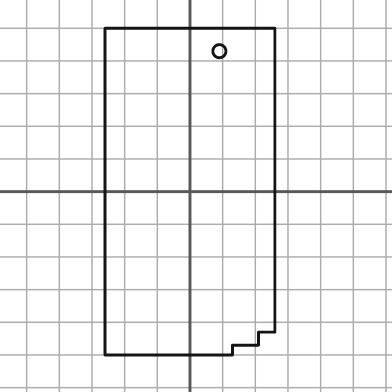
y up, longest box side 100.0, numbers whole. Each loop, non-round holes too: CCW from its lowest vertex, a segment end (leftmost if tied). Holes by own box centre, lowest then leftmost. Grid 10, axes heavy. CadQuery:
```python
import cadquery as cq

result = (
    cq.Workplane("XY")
    .moveTo(-26.0, -50.0)
    .lineTo(13.0, -50.0)
    .lineTo(13.0, -47.0)
    .lineTo(21.0, -47.0)
    .lineTo(21.0, -43.0)
    .lineTo(26.0, -43.0)
    .lineTo(26.0, 50.0)
    .lineTo(-26.0, 50.0)
    .close()
    .moveTo(9.0, 43.0)
    .circle(2.0)
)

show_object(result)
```